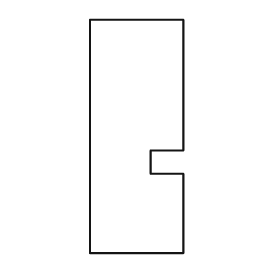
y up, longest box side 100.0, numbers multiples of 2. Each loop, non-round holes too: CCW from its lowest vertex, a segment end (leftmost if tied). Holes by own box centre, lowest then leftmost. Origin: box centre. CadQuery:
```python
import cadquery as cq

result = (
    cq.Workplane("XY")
    .moveTo(-20.0, -50.0)
    .lineTo(20.0, -50.0)
    .lineTo(20.0, -16.0)
    .lineTo(6.0, -16.0)
    .lineTo(6.0, -6.0)
    .lineTo(20.0, -6.0)
    .lineTo(20.0, 50.0)
    .lineTo(-20.0, 50.0)
    .close()
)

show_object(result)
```